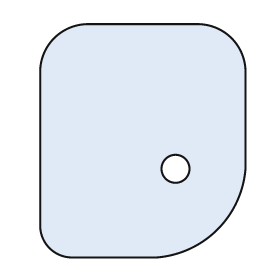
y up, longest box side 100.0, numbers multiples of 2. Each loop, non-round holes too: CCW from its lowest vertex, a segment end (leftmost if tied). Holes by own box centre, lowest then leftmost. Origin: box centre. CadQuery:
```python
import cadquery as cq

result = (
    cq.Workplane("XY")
    .moveTo(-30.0, -50.0)
    .lineTo(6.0, -50.0)
    .threePointArc((32.0, -38.0), (44.0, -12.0))
    .lineTo(44.0, 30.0)
    .threePointArc((38.0, 44.0), (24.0, 50.0))
    .lineTo(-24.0, 50.0)
    .threePointArc((-38.0, 44.0), (-44.0, 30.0))
    .lineTo(-44.0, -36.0)
    .threePointArc((-40.0, -46.0), (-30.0, -50.0))
    .close()
    .moveTo(14.0, -12.0)
    .circle(6.0)
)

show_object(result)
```